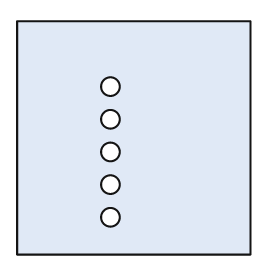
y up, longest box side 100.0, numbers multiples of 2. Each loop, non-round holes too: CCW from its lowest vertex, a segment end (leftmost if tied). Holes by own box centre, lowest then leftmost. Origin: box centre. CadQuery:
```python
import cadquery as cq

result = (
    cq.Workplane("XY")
    .moveTo(-50.0, -50.0)
    .lineTo(50.0, -50.0)
    .lineTo(50.0, 50.0)
    .lineTo(-50.0, 50.0)
    .close()
    .moveTo(-10.0, -34.0)
    .circle(4.0)
    .moveTo(-10.0, -20.0)
    .circle(4.0)
    .moveTo(-10.0, -6.0)
    .circle(4.0)
    .moveTo(-10.0, 8.0)
    .circle(4.0)
    .moveTo(-10.0, 22.0)
    .circle(4.0)
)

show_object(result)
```